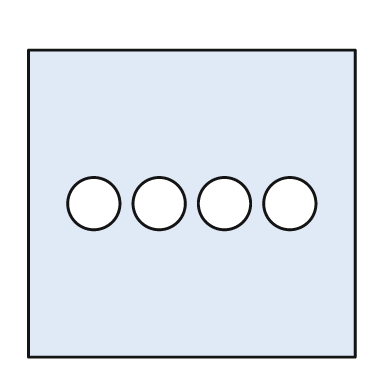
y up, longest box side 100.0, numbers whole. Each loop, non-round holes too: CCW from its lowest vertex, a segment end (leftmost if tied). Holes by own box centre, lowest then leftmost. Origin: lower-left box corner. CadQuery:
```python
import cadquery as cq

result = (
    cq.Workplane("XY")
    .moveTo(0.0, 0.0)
    .lineTo(100.0, 0.0)
    .lineTo(100.0, 94.0)
    .lineTo(0.0, 94.0)
    .close()
    .moveTo(20.0, 47.0)
    .circle(8.0)
    .moveTo(40.0, 47.0)
    .circle(8.0)
    .moveTo(60.0, 47.0)
    .circle(8.0)
    .moveTo(80.0, 47.0)
    .circle(8.0)
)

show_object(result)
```